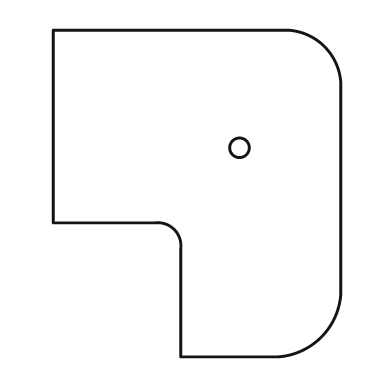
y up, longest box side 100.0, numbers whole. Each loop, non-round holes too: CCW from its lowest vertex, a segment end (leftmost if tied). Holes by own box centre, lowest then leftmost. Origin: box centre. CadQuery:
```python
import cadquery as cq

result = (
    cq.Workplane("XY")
    .moveTo(-5.0, -50.0)
    .lineTo(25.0, -50.0)
    .threePointArc((38.0, -44.0), (44.0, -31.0))
    .lineTo(44.0, 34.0)
    .threePointArc((39.0, 45.0), (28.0, 50.0))
    .lineTo(-44.0, 50.0)
    .lineTo(-44.0, -9.0)
    .lineTo(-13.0, -9.0)
    .threePointArc((-7.0, -11.0), (-5.0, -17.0))
    .close()
    .moveTo(13.0, 14.0)
    .circle(3.0)
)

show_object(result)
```